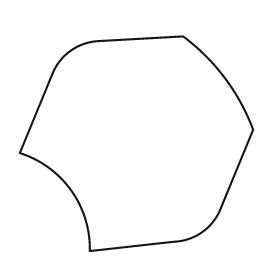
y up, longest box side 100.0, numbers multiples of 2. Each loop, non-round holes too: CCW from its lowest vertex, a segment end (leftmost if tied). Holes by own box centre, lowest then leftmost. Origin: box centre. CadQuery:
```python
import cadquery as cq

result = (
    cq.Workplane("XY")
    .moveTo(-20.0, -46.0)
    .lineTo(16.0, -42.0)
    .threePointArc((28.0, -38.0), (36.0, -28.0))
    .lineTo(50.0, 6.0)
    .threePointArc((38.0, 28.0), (20.0, 46.0))
    .lineTo(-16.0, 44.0)
    .threePointArc((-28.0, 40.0), (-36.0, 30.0))
    .lineTo(-50.0, -4.0)
    .threePointArc((-28.0, -20.0), (-20.0, -46.0))
    .close()
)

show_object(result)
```